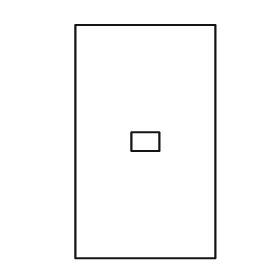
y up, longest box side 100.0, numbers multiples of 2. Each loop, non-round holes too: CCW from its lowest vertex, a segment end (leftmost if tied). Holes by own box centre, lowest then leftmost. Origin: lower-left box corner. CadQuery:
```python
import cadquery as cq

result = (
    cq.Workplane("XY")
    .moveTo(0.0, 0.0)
    .lineTo(60.0, 0.0)
    .lineTo(60.0, 100.0)
    .lineTo(0.0, 100.0)
    .close()
    .moveTo(24.0, 46.0)
    .lineTo(36.0, 46.0)
    .lineTo(36.0, 54.0)
    .lineTo(24.0, 54.0)
    .close()
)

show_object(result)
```